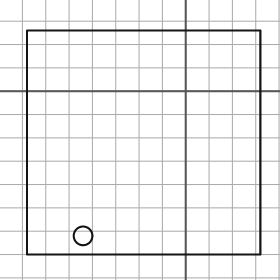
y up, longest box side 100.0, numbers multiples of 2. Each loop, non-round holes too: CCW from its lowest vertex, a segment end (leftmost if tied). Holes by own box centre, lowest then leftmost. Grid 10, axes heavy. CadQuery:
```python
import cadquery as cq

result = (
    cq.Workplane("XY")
    .moveTo(-68.0, -70.0)
    .lineTo(32.0, -70.0)
    .lineTo(32.0, 26.0)
    .lineTo(-68.0, 26.0)
    .close()
    .moveTo(-44.0, -62.0)
    .circle(4.0)
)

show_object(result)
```